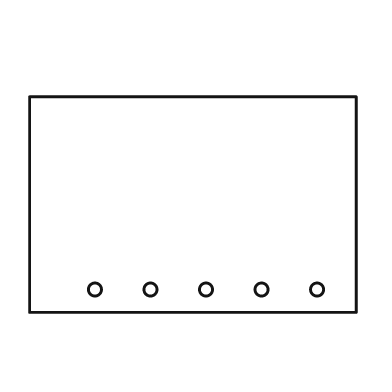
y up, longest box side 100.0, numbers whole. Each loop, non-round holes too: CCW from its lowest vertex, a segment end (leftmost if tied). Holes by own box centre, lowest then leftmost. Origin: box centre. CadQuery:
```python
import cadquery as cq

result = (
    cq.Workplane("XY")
    .moveTo(-50.0, -33.0)
    .lineTo(50.0, -33.0)
    .lineTo(50.0, 33.0)
    .lineTo(-50.0, 33.0)
    .close()
    .moveTo(-30.0, -26.0)
    .circle(2.0)
    .moveTo(-13.0, -26.0)
    .circle(2.0)
    .moveTo(4.0, -26.0)
    .circle(2.0)
    .moveTo(21.0, -26.0)
    .circle(2.0)
    .moveTo(38.0, -26.0)
    .circle(2.0)
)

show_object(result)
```